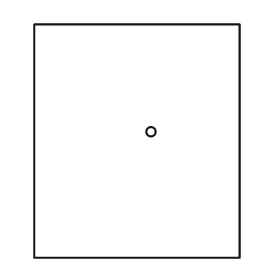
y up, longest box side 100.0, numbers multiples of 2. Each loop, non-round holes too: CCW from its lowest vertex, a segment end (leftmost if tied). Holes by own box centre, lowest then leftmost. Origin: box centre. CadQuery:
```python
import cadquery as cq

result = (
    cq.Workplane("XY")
    .moveTo(-44.0, -50.0)
    .lineTo(44.0, -50.0)
    .lineTo(44.0, 50.0)
    .lineTo(-44.0, 50.0)
    .close()
    .moveTo(6.0, 4.0)
    .circle(2.0)
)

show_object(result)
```